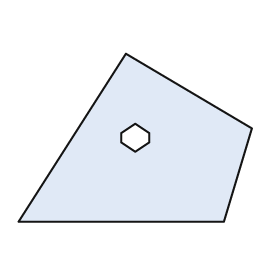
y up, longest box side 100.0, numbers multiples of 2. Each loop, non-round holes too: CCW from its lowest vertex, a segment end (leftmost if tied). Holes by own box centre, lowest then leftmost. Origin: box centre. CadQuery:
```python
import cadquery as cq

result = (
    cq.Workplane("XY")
    .moveTo(-50.0, -36.0)
    .lineTo(38.0, -36.0)
    .lineTo(50.0, 4.0)
    .lineTo(-4.0, 36.0)
    .close()
    .moveTo(0.0, -6.0)
    .lineTo(6.0, -2.0)
    .lineTo(6.0, 2.0)
    .lineTo(0.0, 6.0)
    .lineTo(-6.0, 2.0)
    .lineTo(-6.0, -2.0)
    .close()
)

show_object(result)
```